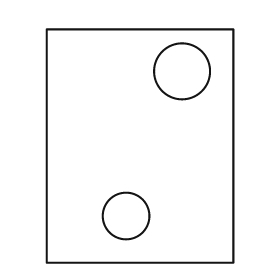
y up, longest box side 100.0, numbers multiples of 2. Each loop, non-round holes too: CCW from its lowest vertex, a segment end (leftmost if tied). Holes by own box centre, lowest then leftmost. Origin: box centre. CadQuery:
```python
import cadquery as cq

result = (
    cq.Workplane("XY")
    .moveTo(-40.0, -50.0)
    .lineTo(40.0, -50.0)
    .lineTo(40.0, 50.0)
    .lineTo(-40.0, 50.0)
    .close()
    .moveTo(-6.0, -30.0)
    .circle(10.0)
    .moveTo(18.0, 32.0)
    .circle(12.0)
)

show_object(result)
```